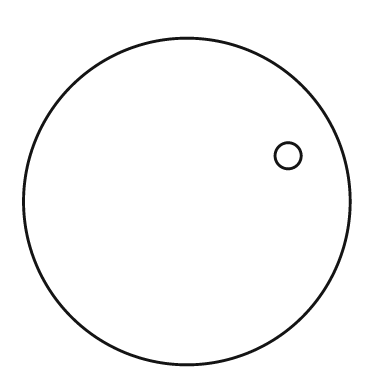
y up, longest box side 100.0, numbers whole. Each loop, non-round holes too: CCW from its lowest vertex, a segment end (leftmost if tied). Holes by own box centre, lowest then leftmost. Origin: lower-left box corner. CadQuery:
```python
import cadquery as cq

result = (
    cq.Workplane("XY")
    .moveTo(50.0, 50.0)
    .circle(50.0)
    .moveTo(81.0, 64.0)
    .circle(4.0)
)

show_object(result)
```